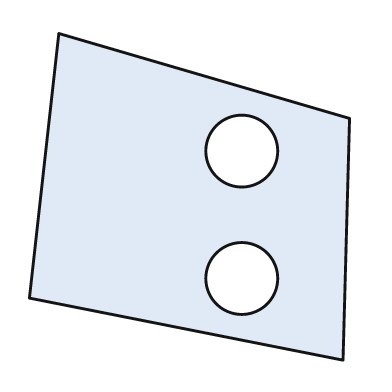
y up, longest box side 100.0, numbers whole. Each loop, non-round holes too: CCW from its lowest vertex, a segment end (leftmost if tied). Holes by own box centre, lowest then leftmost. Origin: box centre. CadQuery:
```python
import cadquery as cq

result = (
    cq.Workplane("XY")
    .moveTo(47.0, -50.0)
    .lineTo(49.0, 24.0)
    .lineTo(-40.0, 50.0)
    .lineTo(-49.0, -31.0)
    .close()
    .moveTo(16.0, -25.0)
    .circle(11.0)
    .moveTo(16.0, 14.0)
    .circle(11.0)
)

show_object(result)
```